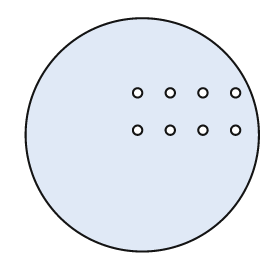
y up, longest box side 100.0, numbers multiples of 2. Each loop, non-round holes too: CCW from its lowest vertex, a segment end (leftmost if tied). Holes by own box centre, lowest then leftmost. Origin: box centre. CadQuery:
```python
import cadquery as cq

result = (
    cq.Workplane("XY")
    .moveTo(0.0, 0.0)
    .circle(50.0)
    .moveTo(-2.0, 2.0)
    .circle(2.0)
    .moveTo(12.0, 2.0)
    .circle(2.0)
    .moveTo(26.0, 2.0)
    .circle(2.0)
    .moveTo(40.0, 2.0)
    .circle(2.0)
    .moveTo(-2.0, 18.0)
    .circle(2.0)
    .moveTo(12.0, 18.0)
    .circle(2.0)
    .moveTo(26.0, 18.0)
    .circle(2.0)
    .moveTo(40.0, 18.0)
    .circle(2.0)
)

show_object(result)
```